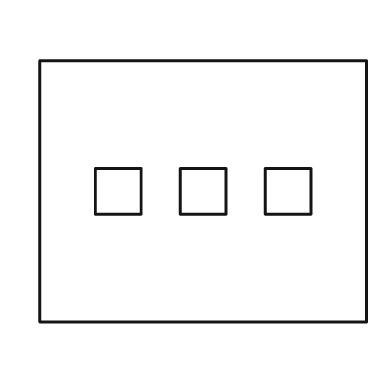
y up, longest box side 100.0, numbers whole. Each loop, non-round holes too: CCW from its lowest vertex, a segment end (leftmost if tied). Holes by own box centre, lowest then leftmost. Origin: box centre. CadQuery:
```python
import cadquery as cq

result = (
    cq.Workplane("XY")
    .moveTo(-50.0, -40.0)
    .lineTo(50.0, -40.0)
    .lineTo(50.0, 40.0)
    .lineTo(-50.0, 40.0)
    .close()
    .moveTo(-33.0, -7.0)
    .lineTo(-19.0, -7.0)
    .lineTo(-19.0, 7.0)
    .lineTo(-33.0, 7.0)
    .close()
    .moveTo(-7.0, -7.0)
    .lineTo(7.0, -7.0)
    .lineTo(7.0, 7.0)
    .lineTo(-7.0, 7.0)
    .close()
    .moveTo(19.0, -7.0)
    .lineTo(33.0, -7.0)
    .lineTo(33.0, 7.0)
    .lineTo(19.0, 7.0)
    .close()
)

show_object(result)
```